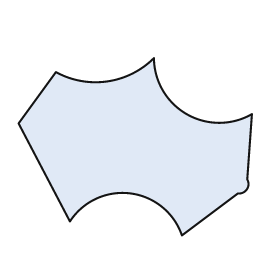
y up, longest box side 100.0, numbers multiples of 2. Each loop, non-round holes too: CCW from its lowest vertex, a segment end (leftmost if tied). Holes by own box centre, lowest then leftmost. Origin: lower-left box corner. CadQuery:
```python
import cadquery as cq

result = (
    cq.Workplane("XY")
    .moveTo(70.0, 0.0)
    .lineTo(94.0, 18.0)
    .threePointArc((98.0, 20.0), (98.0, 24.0))
    .lineTo(100.0, 52.0)
    .threePointArc((72.0, 52.0), (58.0, 76.0))
    .threePointArc((38.0, 66.0), (16.0, 70.0))
    .lineTo(0.0, 48.0)
    .lineTo(22.0, 6.0)
    .threePointArc((48.0, 18.0), (70.0, 0.0))
    .close()
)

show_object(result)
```